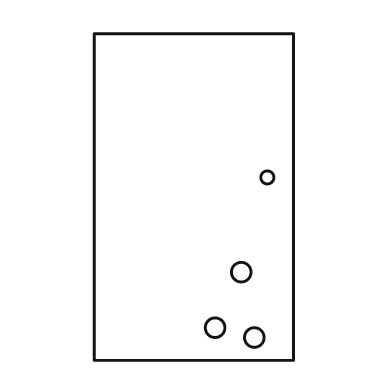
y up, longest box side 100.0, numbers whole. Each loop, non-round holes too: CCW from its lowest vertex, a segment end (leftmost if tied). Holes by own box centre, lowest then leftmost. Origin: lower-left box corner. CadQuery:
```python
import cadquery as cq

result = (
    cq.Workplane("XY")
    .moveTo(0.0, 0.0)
    .lineTo(61.0, 0.0)
    .lineTo(61.0, 100.0)
    .lineTo(0.0, 100.0)
    .close()
    .moveTo(49.0, 7.0)
    .circle(3.0)
    .moveTo(37.0, 10.0)
    .circle(3.0)
    .moveTo(45.0, 27.0)
    .circle(3.0)
    .moveTo(53.0, 56.0)
    .circle(2.0)
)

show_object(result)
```